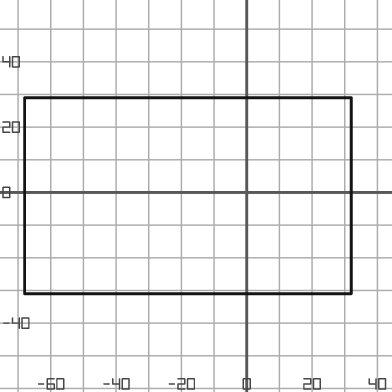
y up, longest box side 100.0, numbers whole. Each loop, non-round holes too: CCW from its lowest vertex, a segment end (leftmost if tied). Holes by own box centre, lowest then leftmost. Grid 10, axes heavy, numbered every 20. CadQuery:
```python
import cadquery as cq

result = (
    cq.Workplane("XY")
    .moveTo(-68.0, -31.0)
    .lineTo(32.0, -31.0)
    .lineTo(32.0, 29.0)
    .lineTo(-68.0, 29.0)
    .close()
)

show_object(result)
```